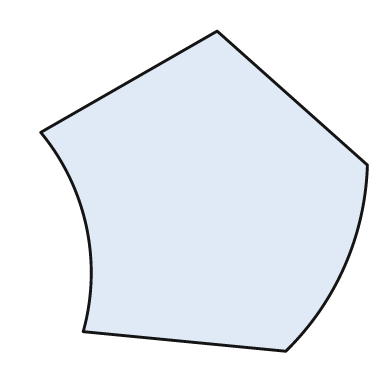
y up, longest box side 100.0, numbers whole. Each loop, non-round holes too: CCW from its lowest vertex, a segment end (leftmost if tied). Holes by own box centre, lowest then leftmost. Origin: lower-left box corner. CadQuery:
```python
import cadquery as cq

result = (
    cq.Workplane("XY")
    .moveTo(75.0, 0.0)
    .threePointArc((93.0, 26.0), (100.0, 57.0))
    .lineTo(54.0, 98.0)
    .lineTo(0.0, 67.0)
    .threePointArc((14.0, 38.0), (13.0, 6.0))
    .close()
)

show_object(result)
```